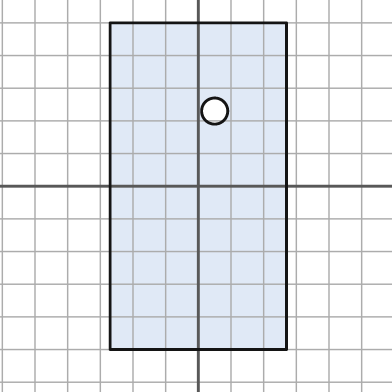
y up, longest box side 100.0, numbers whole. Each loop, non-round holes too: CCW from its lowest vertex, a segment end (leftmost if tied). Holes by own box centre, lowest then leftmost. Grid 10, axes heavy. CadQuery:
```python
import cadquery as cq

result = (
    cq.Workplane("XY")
    .moveTo(-27.0, -50.0)
    .lineTo(27.0, -50.0)
    .lineTo(27.0, 50.0)
    .lineTo(-27.0, 50.0)
    .close()
    .moveTo(5.0, 23.0)
    .circle(4.0)
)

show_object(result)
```